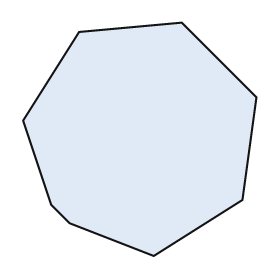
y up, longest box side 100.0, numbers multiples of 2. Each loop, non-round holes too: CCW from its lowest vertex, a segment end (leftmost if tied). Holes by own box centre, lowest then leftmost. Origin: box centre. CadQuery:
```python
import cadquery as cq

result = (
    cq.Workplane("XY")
    .moveTo(6.0, -50.0)
    .lineTo(44.0, -26.0)
    .lineTo(50.0, 18.0)
    .lineTo(18.0, 50.0)
    .lineTo(-26.0, 46.0)
    .lineTo(-50.0, 8.0)
    .lineTo(-38.0, -28.0)
    .lineTo(-30.0, -36.0)
    .close()
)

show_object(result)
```